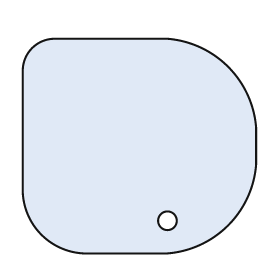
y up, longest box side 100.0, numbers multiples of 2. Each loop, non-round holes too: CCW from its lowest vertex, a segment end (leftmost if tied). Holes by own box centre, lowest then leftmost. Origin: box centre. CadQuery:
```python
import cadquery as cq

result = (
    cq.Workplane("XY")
    .moveTo(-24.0, -46.0)
    .lineTo(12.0, -46.0)
    .threePointArc((38.0, -34.0), (50.0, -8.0))
    .lineTo(50.0, 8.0)
    .threePointArc((38.0, 34.0), (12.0, 46.0))
    .lineTo(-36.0, 46.0)
    .threePointArc((-46.0, 42.0), (-50.0, 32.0))
    .lineTo(-50.0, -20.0)
    .threePointArc((-42.0, -38.0), (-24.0, -46.0))
    .close()
    .moveTo(12.0, -32.0)
    .circle(4.0)
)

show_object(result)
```